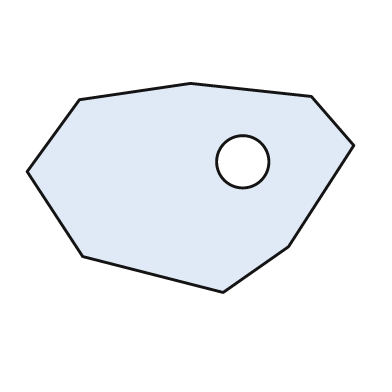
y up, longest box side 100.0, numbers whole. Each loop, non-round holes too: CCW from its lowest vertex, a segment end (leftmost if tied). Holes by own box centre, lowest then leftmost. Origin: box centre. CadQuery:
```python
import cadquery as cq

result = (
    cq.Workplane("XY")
    .moveTo(10.0, -32.0)
    .lineTo(30.0, -18.0)
    .lineTo(50.0, 13.0)
    .lineTo(37.0, 28.0)
    .lineTo(0.0, 32.0)
    .lineTo(-34.0, 27.0)
    .lineTo(-50.0, 5.0)
    .lineTo(-33.0, -21.0)
    .close()
    .moveTo(16.0, 8.0)
    .circle(8.0)
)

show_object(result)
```